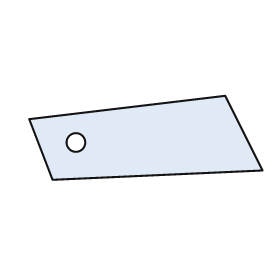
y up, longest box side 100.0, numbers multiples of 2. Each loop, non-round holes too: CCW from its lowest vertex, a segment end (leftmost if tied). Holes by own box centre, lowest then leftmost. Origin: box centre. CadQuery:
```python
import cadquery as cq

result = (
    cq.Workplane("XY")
    .moveTo(-40.0, -18.0)
    .lineTo(50.0, -14.0)
    .lineTo(34.0, 18.0)
    .lineTo(-50.0, 8.0)
    .close()
    .moveTo(-30.0, -2.0)
    .circle(4.0)
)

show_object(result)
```